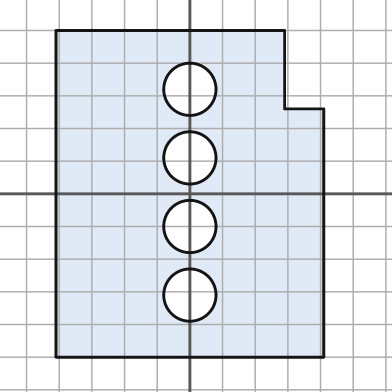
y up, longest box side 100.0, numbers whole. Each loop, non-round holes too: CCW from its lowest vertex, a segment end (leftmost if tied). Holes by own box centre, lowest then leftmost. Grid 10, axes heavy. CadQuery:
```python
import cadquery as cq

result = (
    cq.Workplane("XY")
    .moveTo(-41.0, -50.0)
    .lineTo(41.0, -50.0)
    .lineTo(41.0, 26.0)
    .lineTo(29.0, 26.0)
    .lineTo(29.0, 50.0)
    .lineTo(-41.0, 50.0)
    .close()
    .moveTo(0.0, -31.0)
    .circle(8.0)
    .moveTo(0.0, -10.0)
    .circle(8.0)
    .moveTo(0.0, 11.0)
    .circle(8.0)
    .moveTo(0.0, 32.0)
    .circle(8.0)
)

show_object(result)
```